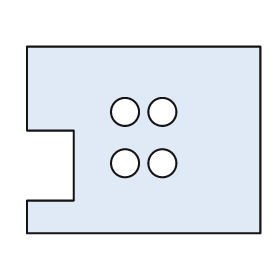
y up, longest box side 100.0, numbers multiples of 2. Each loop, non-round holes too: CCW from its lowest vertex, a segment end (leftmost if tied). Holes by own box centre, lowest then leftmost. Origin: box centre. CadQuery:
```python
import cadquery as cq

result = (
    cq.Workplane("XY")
    .moveTo(-50.0, -40.0)
    .lineTo(50.0, -40.0)
    .lineTo(50.0, 40.0)
    .lineTo(-50.0, 40.0)
    .lineTo(-50.0, 4.0)
    .lineTo(-30.0, 4.0)
    .lineTo(-30.0, -26.0)
    .lineTo(-50.0, -26.0)
    .close()
    .moveTo(-8.0, -10.0)
    .circle(6.0)
    .moveTo(8.0, -10.0)
    .circle(6.0)
    .moveTo(-8.0, 12.0)
    .circle(6.0)
    .moveTo(8.0, 12.0)
    .circle(6.0)
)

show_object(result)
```